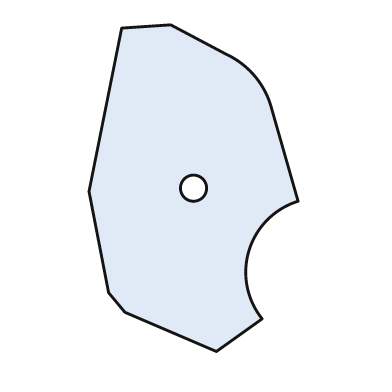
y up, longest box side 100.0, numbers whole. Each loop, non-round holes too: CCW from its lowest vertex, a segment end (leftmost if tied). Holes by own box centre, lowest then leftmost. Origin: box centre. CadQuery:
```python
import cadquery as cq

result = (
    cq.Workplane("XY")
    .moveTo(7.0, -50.0)
    .lineTo(21.0, -40.0)
    .threePointArc((17.0, -19.0), (32.0, -4.0))
    .lineTo(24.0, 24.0)
    .threePointArc((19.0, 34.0), (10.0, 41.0))
    .lineTo(-7.0, 50.0)
    .lineTo(-22.0, 49.0)
    .lineTo(-32.0, -1.0)
    .lineTo(-26.0, -32.0)
    .lineTo(-21.0, -38.0)
    .close()
    .moveTo(0.0, 0.0)
    .circle(4.0)
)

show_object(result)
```